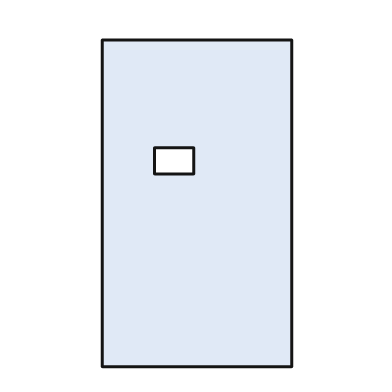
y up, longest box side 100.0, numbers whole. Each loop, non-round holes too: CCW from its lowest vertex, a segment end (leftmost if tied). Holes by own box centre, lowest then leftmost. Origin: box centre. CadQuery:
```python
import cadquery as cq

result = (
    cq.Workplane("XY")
    .moveTo(-29.0, -50.0)
    .lineTo(29.0, -50.0)
    .lineTo(29.0, 50.0)
    .lineTo(-29.0, 50.0)
    .close()
    .moveTo(-13.0, 9.0)
    .lineTo(-1.0, 9.0)
    .lineTo(-1.0, 17.0)
    .lineTo(-13.0, 17.0)
    .close()
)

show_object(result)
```